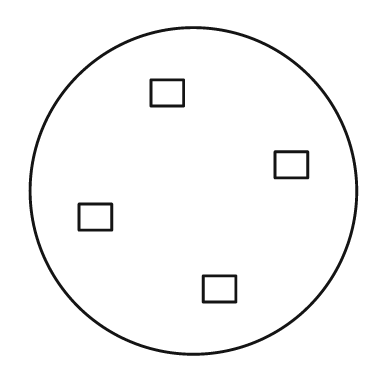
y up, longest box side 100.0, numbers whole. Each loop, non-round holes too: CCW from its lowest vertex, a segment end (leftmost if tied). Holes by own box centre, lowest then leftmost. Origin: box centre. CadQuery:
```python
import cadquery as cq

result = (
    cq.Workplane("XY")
    .moveTo(0.0, 0.0)
    .circle(50.0)
    .moveTo(3.0, -34.0)
    .lineTo(13.0, -34.0)
    .lineTo(13.0, -26.0)
    .lineTo(3.0, -26.0)
    .close()
    .moveTo(-35.0, -12.0)
    .lineTo(-25.0, -12.0)
    .lineTo(-25.0, -4.0)
    .lineTo(-35.0, -4.0)
    .close()
    .moveTo(25.0, 4.0)
    .lineTo(35.0, 4.0)
    .lineTo(35.0, 12.0)
    .lineTo(25.0, 12.0)
    .close()
    .moveTo(-13.0, 26.0)
    .lineTo(-3.0, 26.0)
    .lineTo(-3.0, 34.0)
    .lineTo(-13.0, 34.0)
    .close()
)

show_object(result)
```